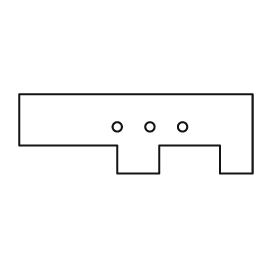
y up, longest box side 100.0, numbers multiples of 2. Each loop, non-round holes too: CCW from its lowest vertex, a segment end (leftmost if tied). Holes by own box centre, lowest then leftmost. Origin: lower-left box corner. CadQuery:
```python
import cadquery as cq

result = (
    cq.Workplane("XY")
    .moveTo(42.0, 0.0)
    .lineTo(60.0, 0.0)
    .lineTo(60.0, 12.0)
    .lineTo(86.0, 12.0)
    .lineTo(86.0, 0.0)
    .lineTo(100.0, 0.0)
    .lineTo(100.0, 34.0)
    .lineTo(0.0, 34.0)
    .lineTo(0.0, 12.0)
    .lineTo(42.0, 12.0)
    .close()
    .moveTo(42.0, 20.0)
    .circle(2.0)
    .moveTo(56.0, 20.0)
    .circle(2.0)
    .moveTo(70.0, 20.0)
    .circle(2.0)
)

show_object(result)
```